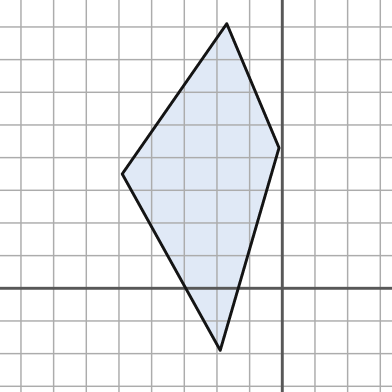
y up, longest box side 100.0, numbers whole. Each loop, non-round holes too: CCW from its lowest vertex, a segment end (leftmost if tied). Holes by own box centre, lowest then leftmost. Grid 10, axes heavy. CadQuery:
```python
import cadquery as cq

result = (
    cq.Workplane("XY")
    .moveTo(-19.0, -19.0)
    .lineTo(-1.0, 43.0)
    .lineTo(-17.0, 81.0)
    .lineTo(-49.0, 35.0)
    .close()
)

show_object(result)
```